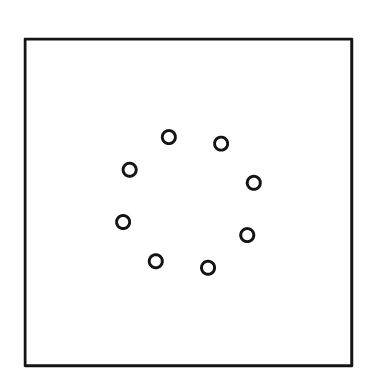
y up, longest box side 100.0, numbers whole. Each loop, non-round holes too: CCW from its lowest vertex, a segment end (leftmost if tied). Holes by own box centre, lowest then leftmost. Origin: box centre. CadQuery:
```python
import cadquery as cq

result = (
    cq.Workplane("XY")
    .moveTo(-50.0, -50.0)
    .lineTo(50.0, -50.0)
    .lineTo(50.0, 50.0)
    .lineTo(-50.0, 50.0)
    .close()
    .moveTo(6.0, -20.0)
    .circle(2.0)
    .moveTo(-10.0, -18.0)
    .circle(2.0)
    .moveTo(18.0, -10.0)
    .circle(2.0)
    .moveTo(-20.0, -6.0)
    .circle(2.0)
    .moveTo(20.0, 6.0)
    .circle(2.0)
    .moveTo(-18.0, 10.0)
    .circle(2.0)
    .moveTo(10.0, 18.0)
    .circle(2.0)
    .moveTo(-6.0, 20.0)
    .circle(2.0)
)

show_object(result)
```